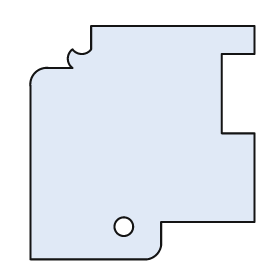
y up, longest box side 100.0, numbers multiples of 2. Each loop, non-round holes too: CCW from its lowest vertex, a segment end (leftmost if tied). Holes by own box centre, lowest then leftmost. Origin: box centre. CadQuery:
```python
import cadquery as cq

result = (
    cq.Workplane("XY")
    .moveTo(-48.0, -50.0)
    .lineTo(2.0, -50.0)
    .threePointArc((6.0, -48.0), (8.0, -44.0))
    .lineTo(8.0, -34.0)
    .lineTo(48.0, -34.0)
    .lineTo(48.0, 4.0)
    .lineTo(34.0, 4.0)
    .lineTo(34.0, 38.0)
    .lineTo(48.0, 38.0)
    .lineTo(48.0, 50.0)
    .lineTo(-22.0, 50.0)
    .lineTo(-22.0, 40.0)
    .threePointArc((-26.0, 38.0), (-30.0, 40.0))
    .threePointArc((-32.0, 36.0), (-30.0, 32.0))
    .lineTo(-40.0, 32.0)
    .threePointArc((-46.0, 30.0), (-48.0, 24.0))
    .close()
    .moveTo(-8.0, -36.0)
    .circle(4.0)
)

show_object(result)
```